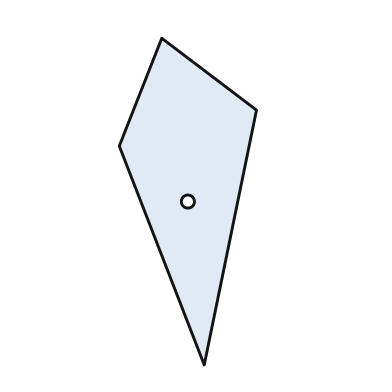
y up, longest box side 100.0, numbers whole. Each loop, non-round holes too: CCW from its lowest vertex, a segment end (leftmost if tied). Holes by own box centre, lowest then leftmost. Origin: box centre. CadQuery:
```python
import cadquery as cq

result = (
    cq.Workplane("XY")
    .moveTo(5.0, -50.0)
    .lineTo(21.0, 28.0)
    .lineTo(-8.0, 50.0)
    .lineTo(-21.0, 17.0)
    .close()
    .moveTo(0.0, 0.0)
    .circle(2.0)
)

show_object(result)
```